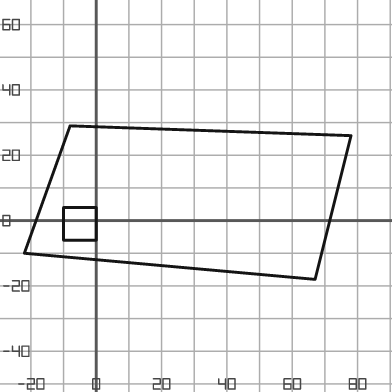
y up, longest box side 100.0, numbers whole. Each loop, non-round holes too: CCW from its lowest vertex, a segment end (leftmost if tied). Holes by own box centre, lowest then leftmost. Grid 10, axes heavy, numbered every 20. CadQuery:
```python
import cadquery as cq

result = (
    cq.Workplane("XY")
    .moveTo(67.0, -18.0)
    .lineTo(78.0, 26.0)
    .lineTo(-8.0, 29.0)
    .lineTo(-22.0, -10.0)
    .close()
    .moveTo(-10.0, -6.0)
    .lineTo(0.0, -6.0)
    .lineTo(0.0, 4.0)
    .lineTo(-10.0, 4.0)
    .close()
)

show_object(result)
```